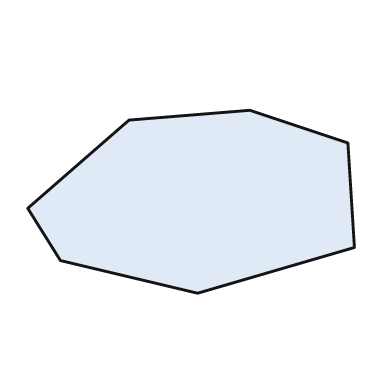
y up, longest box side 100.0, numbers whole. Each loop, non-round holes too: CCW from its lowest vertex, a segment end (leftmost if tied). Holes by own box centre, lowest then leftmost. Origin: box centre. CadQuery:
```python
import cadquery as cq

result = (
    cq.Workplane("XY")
    .moveTo(2.0, -28.0)
    .lineTo(50.0, -14.0)
    .lineTo(48.0, 18.0)
    .lineTo(18.0, 28.0)
    .lineTo(-19.0, 25.0)
    .lineTo(-50.0, -2.0)
    .lineTo(-40.0, -18.0)
    .close()
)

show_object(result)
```